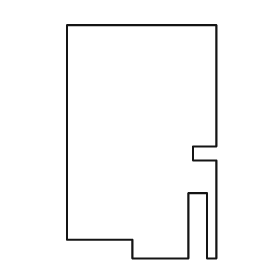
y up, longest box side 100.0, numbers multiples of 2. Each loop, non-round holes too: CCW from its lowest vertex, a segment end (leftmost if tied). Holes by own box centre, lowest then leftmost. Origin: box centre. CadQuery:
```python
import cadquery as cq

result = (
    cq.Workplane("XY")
    .moveTo(-4.0, -50.0)
    .lineTo(20.0, -50.0)
    .lineTo(20.0, -22.0)
    .lineTo(28.0, -22.0)
    .lineTo(28.0, -50.0)
    .lineTo(32.0, -50.0)
    .lineTo(32.0, -8.0)
    .lineTo(22.0, -8.0)
    .lineTo(22.0, -2.0)
    .lineTo(32.0, -2.0)
    .lineTo(32.0, 50.0)
    .lineTo(-32.0, 50.0)
    .lineTo(-32.0, -42.0)
    .lineTo(-4.0, -42.0)
    .close()
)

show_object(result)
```